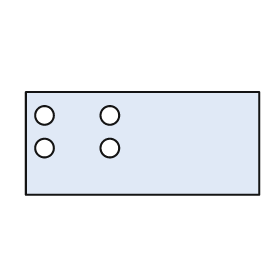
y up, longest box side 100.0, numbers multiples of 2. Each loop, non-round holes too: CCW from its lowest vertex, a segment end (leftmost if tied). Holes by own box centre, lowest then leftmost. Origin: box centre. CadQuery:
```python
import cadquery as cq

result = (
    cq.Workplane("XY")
    .moveTo(-50.0, -22.0)
    .lineTo(50.0, -22.0)
    .lineTo(50.0, 22.0)
    .lineTo(-50.0, 22.0)
    .close()
    .moveTo(-42.0, -2.0)
    .circle(4.0)
    .moveTo(-14.0, -2.0)
    .circle(4.0)
    .moveTo(-42.0, 12.0)
    .circle(4.0)
    .moveTo(-14.0, 12.0)
    .circle(4.0)
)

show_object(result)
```